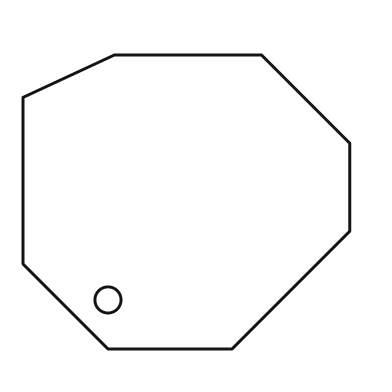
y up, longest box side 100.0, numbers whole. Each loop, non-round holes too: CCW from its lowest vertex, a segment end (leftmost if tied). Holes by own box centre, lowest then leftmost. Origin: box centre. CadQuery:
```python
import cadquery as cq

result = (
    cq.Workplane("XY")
    .moveTo(-24.0, -45.0)
    .lineTo(14.0, -45.0)
    .lineTo(50.0, -9.0)
    .lineTo(50.0, 18.0)
    .lineTo(23.0, 45.0)
    .lineTo(-22.0, 45.0)
    .lineTo(-50.0, 32.0)
    .lineTo(-50.0, -19.0)
    .close()
    .moveTo(-24.0, -30.0)
    .circle(4.0)
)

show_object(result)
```